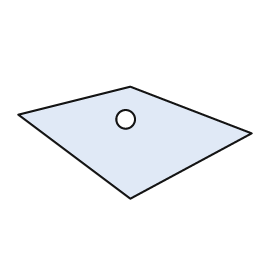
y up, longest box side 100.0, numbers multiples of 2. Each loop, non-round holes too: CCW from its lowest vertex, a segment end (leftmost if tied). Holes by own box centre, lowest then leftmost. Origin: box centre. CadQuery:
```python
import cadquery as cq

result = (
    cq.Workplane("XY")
    .moveTo(-2.0, -24.0)
    .lineTo(50.0, 4.0)
    .lineTo(-2.0, 24.0)
    .lineTo(-50.0, 12.0)
    .close()
    .moveTo(-4.0, 10.0)
    .circle(4.0)
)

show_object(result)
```